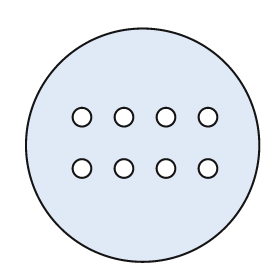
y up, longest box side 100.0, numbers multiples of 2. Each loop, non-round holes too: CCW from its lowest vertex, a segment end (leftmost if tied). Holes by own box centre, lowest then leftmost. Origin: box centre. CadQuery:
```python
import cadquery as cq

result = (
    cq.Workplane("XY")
    .moveTo(0.0, 0.0)
    .circle(50.0)
    .moveTo(-26.0, -10.0)
    .circle(4.0)
    .moveTo(-8.0, -10.0)
    .circle(4.0)
    .moveTo(10.0, -10.0)
    .circle(4.0)
    .moveTo(28.0, -10.0)
    .circle(4.0)
    .moveTo(-26.0, 12.0)
    .circle(4.0)
    .moveTo(-8.0, 12.0)
    .circle(4.0)
    .moveTo(10.0, 12.0)
    .circle(4.0)
    .moveTo(28.0, 12.0)
    .circle(4.0)
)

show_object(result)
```